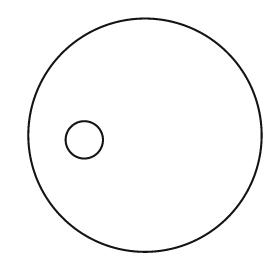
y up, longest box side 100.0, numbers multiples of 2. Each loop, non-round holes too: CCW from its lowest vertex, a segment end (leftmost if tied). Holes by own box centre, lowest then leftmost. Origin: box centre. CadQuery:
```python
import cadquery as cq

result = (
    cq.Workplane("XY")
    .moveTo(0.0, 0.0)
    .circle(50.0)
    .moveTo(-26.0, -2.0)
    .circle(8.0)
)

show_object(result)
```